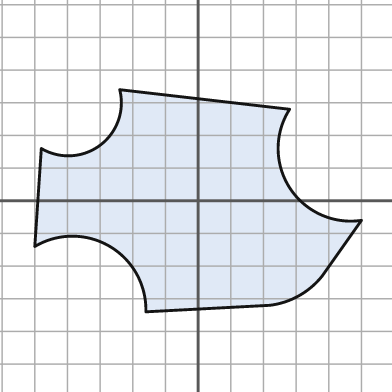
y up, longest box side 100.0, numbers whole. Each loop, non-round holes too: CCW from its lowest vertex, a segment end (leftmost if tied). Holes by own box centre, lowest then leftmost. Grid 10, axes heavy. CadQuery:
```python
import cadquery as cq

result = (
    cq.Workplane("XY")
    .moveTo(-16.0, -34.0)
    .lineTo(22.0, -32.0)
    .threePointArc((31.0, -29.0), (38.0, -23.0))
    .lineTo(50.0, -6.0)
    .threePointArc((28.0, 4.0), (28.0, 28.0))
    .lineTo(-24.0, 34.0)
    .threePointArc((-30.0, 17.0), (-48.0, 16.0))
    .lineTo(-50.0, -14.0)
    .threePointArc((-27.0, -14.0), (-16.0, -34.0))
    .close()
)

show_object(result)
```